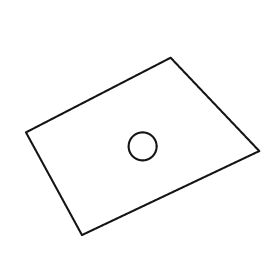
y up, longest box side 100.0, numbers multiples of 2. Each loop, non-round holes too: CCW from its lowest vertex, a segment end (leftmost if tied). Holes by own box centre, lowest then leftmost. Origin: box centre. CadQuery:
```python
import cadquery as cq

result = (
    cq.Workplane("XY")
    .moveTo(-26.0, -38.0)
    .lineTo(50.0, -2.0)
    .lineTo(12.0, 38.0)
    .lineTo(-50.0, 6.0)
    .close()
    .moveTo(0.0, 0.0)
    .circle(6.0)
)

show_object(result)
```